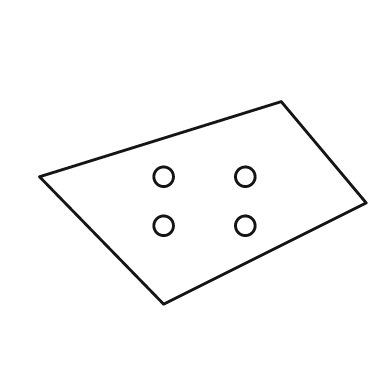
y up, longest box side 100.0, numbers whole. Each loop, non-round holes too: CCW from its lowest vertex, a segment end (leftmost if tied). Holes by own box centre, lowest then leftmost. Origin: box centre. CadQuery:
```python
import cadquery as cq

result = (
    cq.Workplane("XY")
    .moveTo(-12.0, -31.0)
    .lineTo(50.0, 0.0)
    .lineTo(24.0, 31.0)
    .lineTo(-50.0, 8.0)
    .close()
    .moveTo(-12.0, -7.0)
    .circle(3.0)
    .moveTo(13.0, -7.0)
    .circle(3.0)
    .moveTo(-12.0, 8.0)
    .circle(3.0)
    .moveTo(13.0, 8.0)
    .circle(3.0)
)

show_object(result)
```